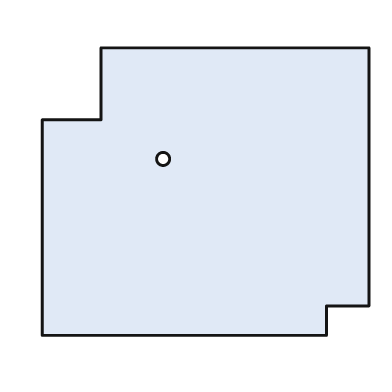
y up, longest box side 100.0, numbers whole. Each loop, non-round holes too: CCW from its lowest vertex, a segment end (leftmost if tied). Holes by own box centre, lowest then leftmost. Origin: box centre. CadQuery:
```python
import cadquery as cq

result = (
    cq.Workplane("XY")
    .moveTo(-50.0, -44.0)
    .lineTo(37.0, -44.0)
    .lineTo(37.0, -35.0)
    .lineTo(50.0, -35.0)
    .lineTo(50.0, 44.0)
    .lineTo(-32.0, 44.0)
    .lineTo(-32.0, 22.0)
    .lineTo(-50.0, 22.0)
    .close()
    .moveTo(-13.0, 10.0)
    .circle(2.0)
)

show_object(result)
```